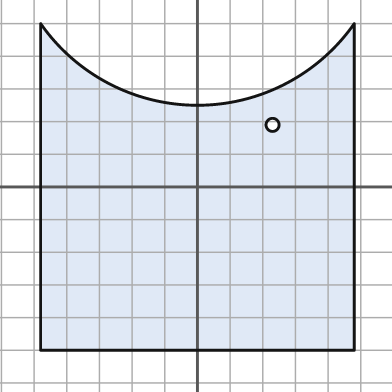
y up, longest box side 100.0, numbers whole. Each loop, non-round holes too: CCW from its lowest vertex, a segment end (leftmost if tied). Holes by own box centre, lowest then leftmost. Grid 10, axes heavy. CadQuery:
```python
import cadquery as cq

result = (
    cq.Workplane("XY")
    .moveTo(-48.0, -50.0)
    .lineTo(48.0, -50.0)
    .lineTo(48.0, 50.0)
    .threePointArc((0.0, 25.0), (-48.0, 50.0))
    .close()
    .moveTo(23.0, 19.0)
    .circle(2.0)
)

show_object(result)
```